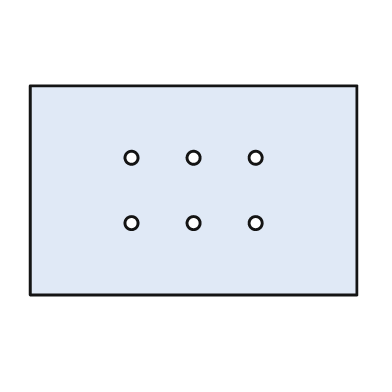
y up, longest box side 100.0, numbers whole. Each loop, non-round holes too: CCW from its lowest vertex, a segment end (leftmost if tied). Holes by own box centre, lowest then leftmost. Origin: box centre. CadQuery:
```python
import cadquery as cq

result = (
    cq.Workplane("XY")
    .moveTo(-50.0, -32.0)
    .lineTo(50.0, -32.0)
    .lineTo(50.0, 32.0)
    .lineTo(-50.0, 32.0)
    .close()
    .moveTo(-19.0, -10.0)
    .circle(2.0)
    .moveTo(0.0, -10.0)
    .circle(2.0)
    .moveTo(19.0, -10.0)
    .circle(2.0)
    .moveTo(-19.0, 10.0)
    .circle(2.0)
    .moveTo(0.0, 10.0)
    .circle(2.0)
    .moveTo(19.0, 10.0)
    .circle(2.0)
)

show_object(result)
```